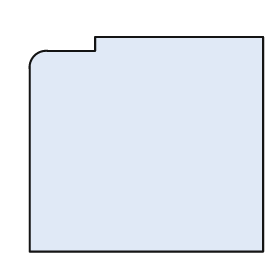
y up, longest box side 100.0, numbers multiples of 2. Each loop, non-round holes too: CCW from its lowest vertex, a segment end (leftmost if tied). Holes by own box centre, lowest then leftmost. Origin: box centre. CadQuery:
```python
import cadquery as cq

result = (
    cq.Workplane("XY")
    .moveTo(-50.0, -46.0)
    .lineTo(50.0, -46.0)
    .lineTo(50.0, 46.0)
    .lineTo(-22.0, 46.0)
    .lineTo(-22.0, 40.0)
    .lineTo(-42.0, 40.0)
    .threePointArc((-48.0, 38.0), (-50.0, 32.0))
    .close()
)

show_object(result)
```